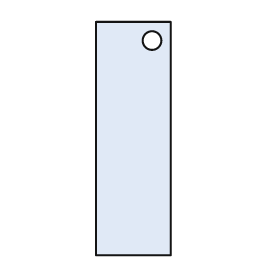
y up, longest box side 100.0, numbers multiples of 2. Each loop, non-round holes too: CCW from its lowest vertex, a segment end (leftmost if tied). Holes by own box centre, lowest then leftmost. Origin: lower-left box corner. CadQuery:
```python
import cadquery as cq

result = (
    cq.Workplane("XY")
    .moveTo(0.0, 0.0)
    .lineTo(32.0, 0.0)
    .lineTo(32.0, 100.0)
    .lineTo(0.0, 100.0)
    .close()
    .moveTo(24.0, 92.0)
    .circle(4.0)
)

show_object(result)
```